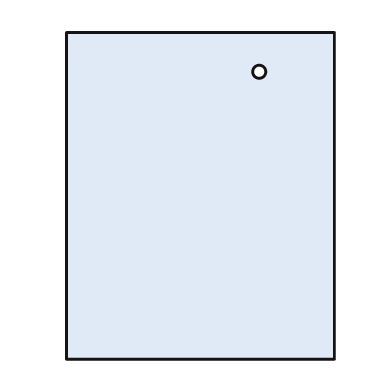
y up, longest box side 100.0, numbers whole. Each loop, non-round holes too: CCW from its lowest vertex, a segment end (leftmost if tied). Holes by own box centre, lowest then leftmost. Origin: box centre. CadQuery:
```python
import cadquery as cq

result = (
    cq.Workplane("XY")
    .moveTo(-41.0, -50.0)
    .lineTo(41.0, -50.0)
    .lineTo(41.0, 50.0)
    .lineTo(-41.0, 50.0)
    .close()
    .moveTo(18.0, 38.0)
    .circle(2.0)
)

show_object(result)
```